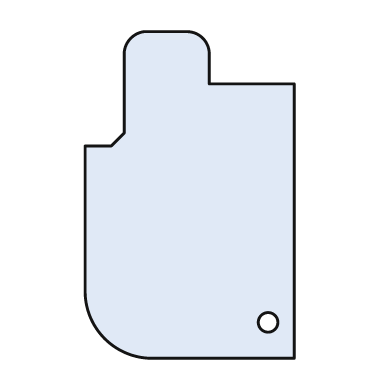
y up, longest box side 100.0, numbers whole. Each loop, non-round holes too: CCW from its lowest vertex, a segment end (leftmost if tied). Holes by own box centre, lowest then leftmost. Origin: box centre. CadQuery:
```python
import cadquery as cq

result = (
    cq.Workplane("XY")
    .moveTo(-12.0, -50.0)
    .lineTo(32.0, -50.0)
    .lineTo(32.0, 34.0)
    .lineTo(6.0, 34.0)
    .lineTo(6.0, 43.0)
    .threePointArc((4.0, 48.0), (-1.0, 50.0))
    .lineTo(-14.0, 50.0)
    .threePointArc((-18.0, 48.0), (-20.0, 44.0))
    .lineTo(-20.0, 19.0)
    .lineTo(-24.0, 15.0)
    .lineTo(-32.0, 15.0)
    .lineTo(-32.0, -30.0)
    .threePointArc((-26.0, -44.0), (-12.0, -50.0))
    .close()
    .moveTo(24.0, -39.0)
    .circle(3.0)
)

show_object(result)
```